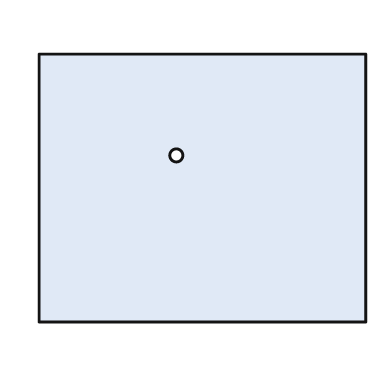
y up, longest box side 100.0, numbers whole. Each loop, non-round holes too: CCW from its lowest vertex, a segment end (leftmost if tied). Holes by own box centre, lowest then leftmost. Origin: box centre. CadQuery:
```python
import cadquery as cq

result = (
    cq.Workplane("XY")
    .moveTo(-50.0, -41.0)
    .lineTo(50.0, -41.0)
    .lineTo(50.0, 41.0)
    .lineTo(-50.0, 41.0)
    .close()
    .moveTo(-8.0, 10.0)
    .circle(2.0)
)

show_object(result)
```